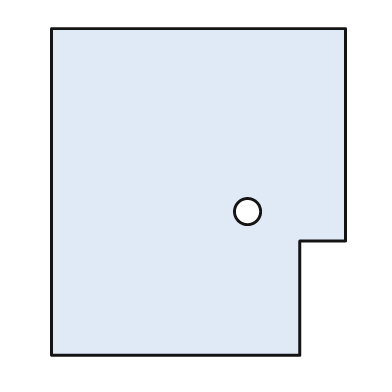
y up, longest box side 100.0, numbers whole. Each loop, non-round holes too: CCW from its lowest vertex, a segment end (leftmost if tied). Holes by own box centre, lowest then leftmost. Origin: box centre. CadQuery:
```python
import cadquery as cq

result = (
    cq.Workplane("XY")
    .moveTo(-45.0, -50.0)
    .lineTo(31.0, -50.0)
    .lineTo(31.0, -15.0)
    .lineTo(45.0, -15.0)
    .lineTo(45.0, 50.0)
    .lineTo(-45.0, 50.0)
    .close()
    .moveTo(15.0, -6.0)
    .circle(4.0)
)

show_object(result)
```